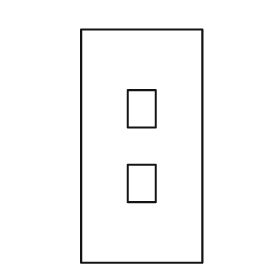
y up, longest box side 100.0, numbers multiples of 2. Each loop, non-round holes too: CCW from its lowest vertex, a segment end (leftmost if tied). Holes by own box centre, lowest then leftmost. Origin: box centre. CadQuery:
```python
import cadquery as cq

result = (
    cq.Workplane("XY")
    .moveTo(-26.0, -50.0)
    .lineTo(26.0, -50.0)
    .lineTo(26.0, 50.0)
    .lineTo(-26.0, 50.0)
    .close()
    .moveTo(-6.0, -24.0)
    .lineTo(6.0, -24.0)
    .lineTo(6.0, -8.0)
    .lineTo(-6.0, -8.0)
    .close()
    .moveTo(-6.0, 8.0)
    .lineTo(6.0, 8.0)
    .lineTo(6.0, 24.0)
    .lineTo(-6.0, 24.0)
    .close()
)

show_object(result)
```